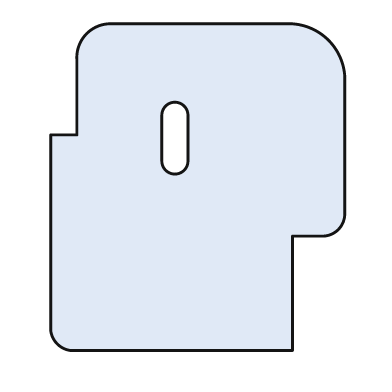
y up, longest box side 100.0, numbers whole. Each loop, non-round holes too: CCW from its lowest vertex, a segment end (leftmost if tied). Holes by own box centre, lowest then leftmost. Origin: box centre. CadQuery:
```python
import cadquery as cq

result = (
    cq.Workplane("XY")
    .moveTo(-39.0, -50.0)
    .lineTo(29.0, -50.0)
    .lineTo(29.0, -15.0)
    .lineTo(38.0, -15.0)
    .threePointArc((43.0, -13.0), (45.0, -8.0))
    .lineTo(45.0, 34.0)
    .threePointArc((40.0, 45.0), (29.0, 50.0))
    .lineTo(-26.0, 50.0)
    .threePointArc((-34.0, 47.0), (-37.0, 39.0))
    .lineTo(-37.0, 16.0)
    .lineTo(-45.0, 16.0)
    .lineTo(-45.0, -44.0)
    .threePointArc((-43.0, -48.0), (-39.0, -50.0))
    .close()
    .moveTo(-11.0, 8.0)
    .threePointArc((-7.0, 4.0), (-3.0, 8.0))
    .lineTo(-3.0, 22.0)
    .threePointArc((-7.0, 26.0), (-11.0, 22.0))
    .close()
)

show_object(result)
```